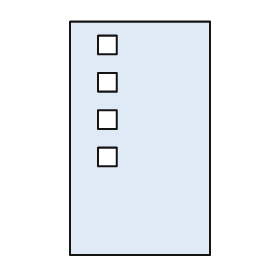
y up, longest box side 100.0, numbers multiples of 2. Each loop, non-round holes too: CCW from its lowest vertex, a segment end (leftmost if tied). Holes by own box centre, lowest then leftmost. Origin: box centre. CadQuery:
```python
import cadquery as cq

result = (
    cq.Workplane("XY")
    .moveTo(-30.0, -50.0)
    .lineTo(30.0, -50.0)
    .lineTo(30.0, 50.0)
    .lineTo(-30.0, 50.0)
    .close()
    .moveTo(-18.0, -12.0)
    .lineTo(-10.0, -12.0)
    .lineTo(-10.0, -4.0)
    .lineTo(-18.0, -4.0)
    .close()
    .moveTo(-18.0, 4.0)
    .lineTo(-10.0, 4.0)
    .lineTo(-10.0, 12.0)
    .lineTo(-18.0, 12.0)
    .close()
    .moveTo(-18.0, 20.0)
    .lineTo(-10.0, 20.0)
    .lineTo(-10.0, 28.0)
    .lineTo(-18.0, 28.0)
    .close()
    .moveTo(-18.0, 36.0)
    .lineTo(-10.0, 36.0)
    .lineTo(-10.0, 44.0)
    .lineTo(-18.0, 44.0)
    .close()
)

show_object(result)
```